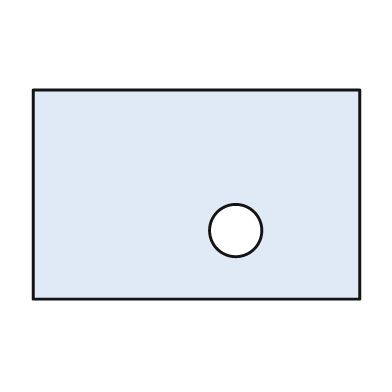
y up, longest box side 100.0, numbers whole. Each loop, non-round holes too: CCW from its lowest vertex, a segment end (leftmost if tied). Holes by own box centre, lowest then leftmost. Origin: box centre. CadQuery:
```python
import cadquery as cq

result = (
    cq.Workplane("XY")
    .moveTo(-50.0, -32.0)
    .lineTo(50.0, -32.0)
    .lineTo(50.0, 32.0)
    .lineTo(-50.0, 32.0)
    .close()
    .moveTo(12.0, -11.0)
    .circle(8.0)
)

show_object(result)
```